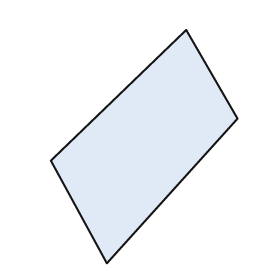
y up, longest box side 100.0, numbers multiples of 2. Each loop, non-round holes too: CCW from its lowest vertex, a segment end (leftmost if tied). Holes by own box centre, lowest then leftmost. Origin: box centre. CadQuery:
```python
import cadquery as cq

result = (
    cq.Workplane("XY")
    .moveTo(-16.0, -50.0)
    .lineTo(40.0, 12.0)
    .lineTo(18.0, 50.0)
    .lineTo(-40.0, -6.0)
    .close()
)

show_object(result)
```